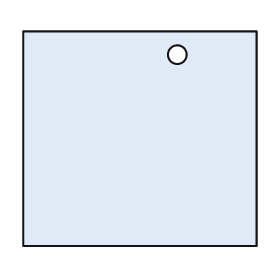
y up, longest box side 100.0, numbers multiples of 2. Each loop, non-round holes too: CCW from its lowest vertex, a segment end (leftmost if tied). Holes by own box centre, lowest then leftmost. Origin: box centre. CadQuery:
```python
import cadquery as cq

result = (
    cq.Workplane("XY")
    .moveTo(-50.0, -46.0)
    .lineTo(50.0, -46.0)
    .lineTo(50.0, 46.0)
    .lineTo(-50.0, 46.0)
    .close()
    .moveTo(16.0, 36.0)
    .circle(4.0)
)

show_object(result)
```